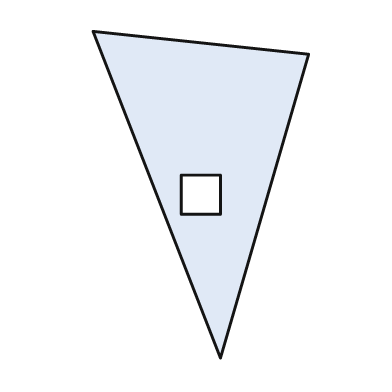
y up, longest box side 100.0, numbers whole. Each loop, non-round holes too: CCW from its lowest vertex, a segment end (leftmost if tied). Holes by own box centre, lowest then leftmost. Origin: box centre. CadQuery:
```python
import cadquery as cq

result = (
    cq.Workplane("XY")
    .moveTo(6.0, -50.0)
    .lineTo(33.0, 43.0)
    .lineTo(-33.0, 50.0)
    .close()
    .moveTo(-6.0, -6.0)
    .lineTo(6.0, -6.0)
    .lineTo(6.0, 6.0)
    .lineTo(-6.0, 6.0)
    .close()
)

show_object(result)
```